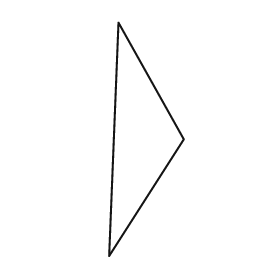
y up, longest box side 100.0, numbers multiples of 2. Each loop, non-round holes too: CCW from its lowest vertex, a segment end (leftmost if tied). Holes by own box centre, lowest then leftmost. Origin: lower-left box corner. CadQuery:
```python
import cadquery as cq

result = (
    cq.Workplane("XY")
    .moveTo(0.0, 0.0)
    .lineTo(32.0, 50.0)
    .lineTo(4.0, 100.0)
    .close()
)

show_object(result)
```